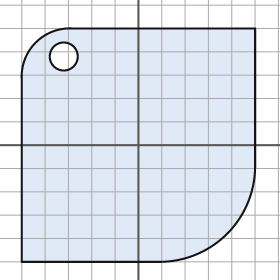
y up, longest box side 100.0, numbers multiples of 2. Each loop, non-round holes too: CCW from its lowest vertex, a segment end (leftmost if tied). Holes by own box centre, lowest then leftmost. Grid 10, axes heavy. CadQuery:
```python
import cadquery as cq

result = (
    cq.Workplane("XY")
    .moveTo(-50.0, -50.0)
    .lineTo(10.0, -50.0)
    .threePointArc((38.0, -38.0), (50.0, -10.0))
    .lineTo(50.0, 50.0)
    .lineTo(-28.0, 50.0)
    .threePointArc((-44.0, 44.0), (-50.0, 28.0))
    .close()
    .moveTo(-32.0, 38.0)
    .circle(6.0)
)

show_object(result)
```